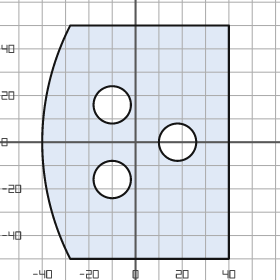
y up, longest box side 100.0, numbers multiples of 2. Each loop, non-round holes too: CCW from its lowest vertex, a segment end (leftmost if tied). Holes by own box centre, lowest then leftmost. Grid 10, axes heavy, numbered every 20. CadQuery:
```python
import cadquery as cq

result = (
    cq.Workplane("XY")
    .moveTo(-28.0, -50.0)
    .lineTo(40.0, -50.0)
    .lineTo(40.0, 50.0)
    .lineTo(-28.0, 50.0)
    .threePointArc((-40.0, 0.0), (-28.0, -50.0))
    .close()
    .moveTo(-10.0, -16.0)
    .circle(8.0)
    .moveTo(18.0, 0.0)
    .circle(8.0)
    .moveTo(-10.0, 16.0)
    .circle(8.0)
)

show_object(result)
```